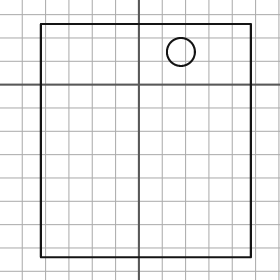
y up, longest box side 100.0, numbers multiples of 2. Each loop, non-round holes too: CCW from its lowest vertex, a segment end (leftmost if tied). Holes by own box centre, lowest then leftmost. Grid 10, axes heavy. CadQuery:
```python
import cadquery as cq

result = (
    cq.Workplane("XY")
    .moveTo(-42.0, -74.0)
    .lineTo(48.0, -74.0)
    .lineTo(48.0, 26.0)
    .lineTo(-42.0, 26.0)
    .close()
    .moveTo(18.0, 14.0)
    .circle(6.0)
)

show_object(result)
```